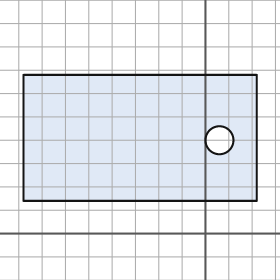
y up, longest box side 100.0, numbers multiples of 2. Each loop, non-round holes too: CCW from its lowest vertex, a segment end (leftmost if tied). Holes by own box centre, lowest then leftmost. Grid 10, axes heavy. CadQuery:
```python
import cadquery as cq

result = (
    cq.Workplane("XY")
    .moveTo(-78.0, 14.0)
    .lineTo(22.0, 14.0)
    .lineTo(22.0, 68.0)
    .lineTo(-78.0, 68.0)
    .close()
    .moveTo(6.0, 40.0)
    .circle(6.0)
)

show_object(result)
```